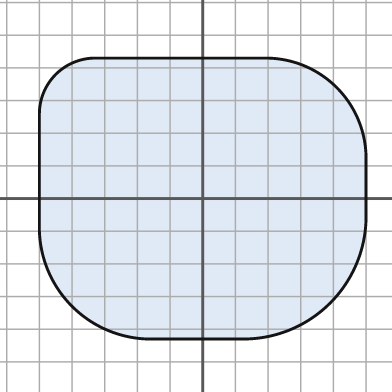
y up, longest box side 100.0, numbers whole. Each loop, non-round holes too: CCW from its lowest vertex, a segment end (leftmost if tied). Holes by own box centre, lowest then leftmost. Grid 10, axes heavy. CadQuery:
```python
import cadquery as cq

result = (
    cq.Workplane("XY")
    .moveTo(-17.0, -43.0)
    .lineTo(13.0, -43.0)
    .threePointArc((39.0, -32.0), (50.0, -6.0))
    .lineTo(50.0, 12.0)
    .threePointArc((41.0, 34.0), (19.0, 43.0))
    .lineTo(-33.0, 43.0)
    .threePointArc((-45.0, 38.0), (-50.0, 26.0))
    .lineTo(-50.0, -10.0)
    .threePointArc((-40.0, -33.0), (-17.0, -43.0))
    .close()
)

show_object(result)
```